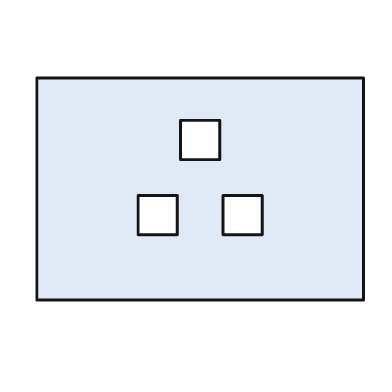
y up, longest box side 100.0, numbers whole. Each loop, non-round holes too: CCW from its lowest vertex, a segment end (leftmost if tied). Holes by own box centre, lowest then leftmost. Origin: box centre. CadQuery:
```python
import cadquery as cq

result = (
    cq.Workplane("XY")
    .moveTo(-50.0, -34.0)
    .lineTo(50.0, -34.0)
    .lineTo(50.0, 34.0)
    .lineTo(-50.0, 34.0)
    .close()
    .moveTo(-19.0, -14.0)
    .lineTo(-7.0, -14.0)
    .lineTo(-7.0, -2.0)
    .lineTo(-19.0, -2.0)
    .close()
    .moveTo(7.0, -14.0)
    .lineTo(19.0, -14.0)
    .lineTo(19.0, -2.0)
    .lineTo(7.0, -2.0)
    .close()
    .moveTo(-6.0, 9.0)
    .lineTo(6.0, 9.0)
    .lineTo(6.0, 21.0)
    .lineTo(-6.0, 21.0)
    .close()
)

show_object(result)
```